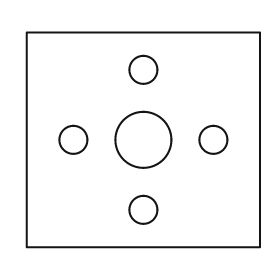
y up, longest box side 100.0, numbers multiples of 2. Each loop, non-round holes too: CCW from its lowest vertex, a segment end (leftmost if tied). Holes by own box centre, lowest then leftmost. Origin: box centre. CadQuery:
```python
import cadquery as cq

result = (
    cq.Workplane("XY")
    .moveTo(-50.0, -46.0)
    .lineTo(50.0, -46.0)
    .lineTo(50.0, 46.0)
    .lineTo(-50.0, 46.0)
    .close()
    .moveTo(0.0, -30.0)
    .circle(6.0)
    .moveTo(-30.0, 0.0)
    .circle(6.0)
    .moveTo(0.0, 0.0)
    .circle(12.0)
    .moveTo(30.0, 0.0)
    .circle(6.0)
    .moveTo(0.0, 30.0)
    .circle(6.0)
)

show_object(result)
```